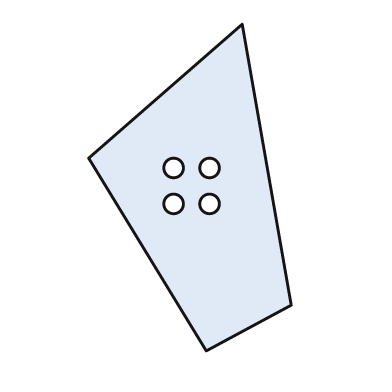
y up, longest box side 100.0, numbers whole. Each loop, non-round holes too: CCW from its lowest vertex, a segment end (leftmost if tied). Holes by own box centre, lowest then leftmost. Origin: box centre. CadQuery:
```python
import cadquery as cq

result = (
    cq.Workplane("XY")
    .moveTo(5.0, -50.0)
    .lineTo(31.0, -36.0)
    .lineTo(16.0, 50.0)
    .lineTo(-31.0, 9.0)
    .close()
    .moveTo(-5.0, -5.0)
    .circle(3.0)
    .moveTo(6.0, -5.0)
    .circle(3.0)
    .moveTo(-5.0, 6.0)
    .circle(3.0)
    .moveTo(6.0, 6.0)
    .circle(3.0)
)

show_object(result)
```